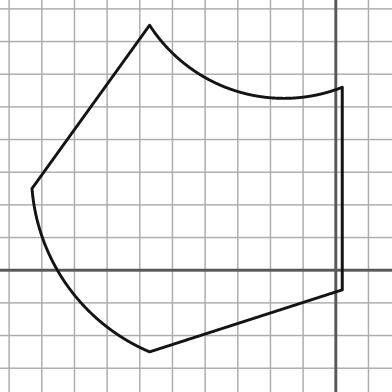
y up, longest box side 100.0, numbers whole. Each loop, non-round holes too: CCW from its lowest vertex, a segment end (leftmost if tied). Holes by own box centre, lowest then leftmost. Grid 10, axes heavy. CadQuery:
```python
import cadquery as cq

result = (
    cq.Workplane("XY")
    .moveTo(-57.0, -25.0)
    .lineTo(2.0, -6.0)
    .lineTo(2.0, 56.0)
    .threePointArc((-31.0, 55.0), (-57.0, 75.0))
    .lineTo(-93.0, 25.0)
    .threePointArc((-82.0, -5.0), (-57.0, -25.0))
    .close()
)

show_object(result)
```